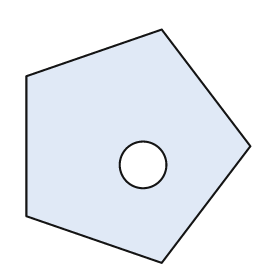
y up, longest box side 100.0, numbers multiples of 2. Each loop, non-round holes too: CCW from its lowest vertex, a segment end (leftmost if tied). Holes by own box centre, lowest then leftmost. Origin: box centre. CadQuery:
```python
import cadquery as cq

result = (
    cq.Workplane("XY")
    .moveTo(10.0, -50.0)
    .lineTo(48.0, 0.0)
    .lineTo(10.0, 50.0)
    .lineTo(-48.0, 30.0)
    .lineTo(-48.0, -30.0)
    .close()
    .moveTo(2.0, -8.0)
    .circle(10.0)
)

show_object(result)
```